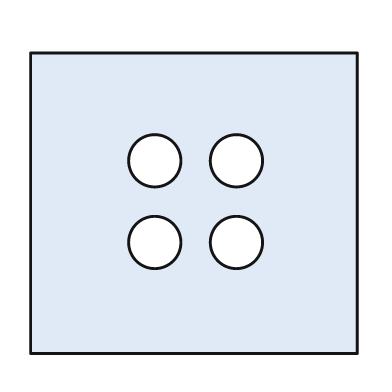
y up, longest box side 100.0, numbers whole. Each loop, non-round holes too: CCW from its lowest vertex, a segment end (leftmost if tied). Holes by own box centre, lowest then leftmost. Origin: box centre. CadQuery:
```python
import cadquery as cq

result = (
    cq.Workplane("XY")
    .moveTo(-50.0, -46.0)
    .lineTo(50.0, -46.0)
    .lineTo(50.0, 46.0)
    .lineTo(-50.0, 46.0)
    .close()
    .moveTo(-12.0, -12.0)
    .circle(8.0)
    .moveTo(13.0, -12.0)
    .circle(8.0)
    .moveTo(-12.0, 13.0)
    .circle(8.0)
    .moveTo(13.0, 13.0)
    .circle(8.0)
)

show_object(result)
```